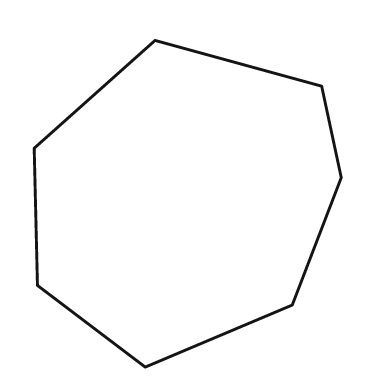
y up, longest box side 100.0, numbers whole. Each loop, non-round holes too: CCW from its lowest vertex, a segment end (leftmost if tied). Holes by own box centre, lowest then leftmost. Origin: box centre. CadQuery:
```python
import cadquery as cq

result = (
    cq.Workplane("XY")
    .moveTo(-13.0, -50.0)
    .lineTo(32.0, -31.0)
    .lineTo(47.0, 8.0)
    .lineTo(41.0, 36.0)
    .lineTo(-10.0, 50.0)
    .lineTo(-47.0, 17.0)
    .lineTo(-46.0, -25.0)
    .close()
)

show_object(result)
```